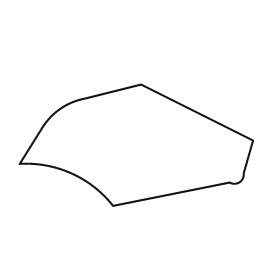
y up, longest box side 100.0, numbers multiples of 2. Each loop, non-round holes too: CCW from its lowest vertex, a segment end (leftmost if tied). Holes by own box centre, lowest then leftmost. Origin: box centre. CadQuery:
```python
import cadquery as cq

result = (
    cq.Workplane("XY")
    .moveTo(-10.0, -26.0)
    .lineTo(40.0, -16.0)
    .threePointArc((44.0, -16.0), (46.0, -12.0))
    .lineTo(50.0, 2.0)
    .lineTo(2.0, 26.0)
    .lineTo(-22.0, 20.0)
    .threePointArc((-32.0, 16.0), (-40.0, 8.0))
    .lineTo(-50.0, -8.0)
    .threePointArc((-28.0, -12.0), (-10.0, -26.0))
    .close()
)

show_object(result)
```